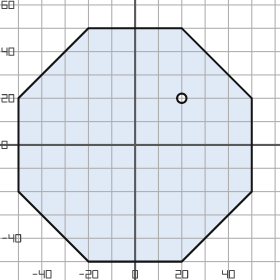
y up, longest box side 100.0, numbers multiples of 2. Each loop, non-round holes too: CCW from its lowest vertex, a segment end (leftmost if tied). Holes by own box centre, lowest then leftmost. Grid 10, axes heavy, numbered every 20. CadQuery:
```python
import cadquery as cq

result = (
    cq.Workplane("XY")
    .moveTo(-20.0, -50.0)
    .lineTo(20.0, -50.0)
    .lineTo(50.0, -20.0)
    .lineTo(50.0, 20.0)
    .lineTo(20.0, 50.0)
    .lineTo(-20.0, 50.0)
    .lineTo(-50.0, 20.0)
    .lineTo(-50.0, -20.0)
    .close()
    .moveTo(20.0, 20.0)
    .circle(2.0)
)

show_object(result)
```